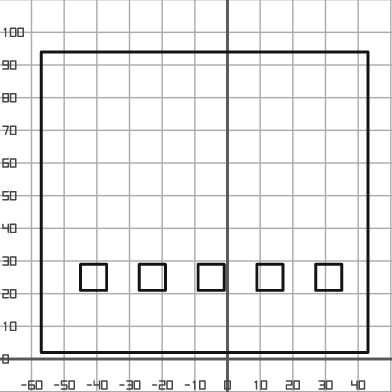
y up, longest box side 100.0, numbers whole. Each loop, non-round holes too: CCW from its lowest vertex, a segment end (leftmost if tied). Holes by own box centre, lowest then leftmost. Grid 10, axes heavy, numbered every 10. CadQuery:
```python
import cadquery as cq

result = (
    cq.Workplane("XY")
    .moveTo(-57.0, 2.0)
    .lineTo(43.0, 2.0)
    .lineTo(43.0, 94.0)
    .lineTo(-57.0, 94.0)
    .close()
    .moveTo(-45.0, 21.0)
    .lineTo(-37.0, 21.0)
    .lineTo(-37.0, 29.0)
    .lineTo(-45.0, 29.0)
    .close()
    .moveTo(-27.0, 21.0)
    .lineTo(-19.0, 21.0)
    .lineTo(-19.0, 29.0)
    .lineTo(-27.0, 29.0)
    .close()
    .moveTo(-9.0, 21.0)
    .lineTo(-1.0, 21.0)
    .lineTo(-1.0, 29.0)
    .lineTo(-9.0, 29.0)
    .close()
    .moveTo(9.0, 21.0)
    .lineTo(17.0, 21.0)
    .lineTo(17.0, 29.0)
    .lineTo(9.0, 29.0)
    .close()
    .moveTo(27.0, 21.0)
    .lineTo(35.0, 21.0)
    .lineTo(35.0, 29.0)
    .lineTo(27.0, 29.0)
    .close()
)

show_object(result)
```